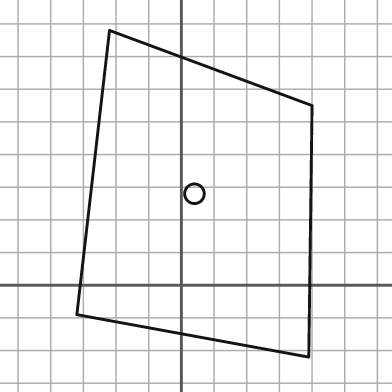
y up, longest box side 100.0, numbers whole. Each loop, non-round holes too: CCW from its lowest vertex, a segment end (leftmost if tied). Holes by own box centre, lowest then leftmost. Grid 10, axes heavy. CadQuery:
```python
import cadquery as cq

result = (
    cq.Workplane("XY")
    .moveTo(39.0, -22.0)
    .lineTo(40.0, 55.0)
    .lineTo(-22.0, 78.0)
    .lineTo(-32.0, -9.0)
    .close()
    .moveTo(4.0, 28.0)
    .circle(3.0)
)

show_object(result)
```